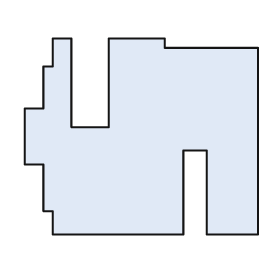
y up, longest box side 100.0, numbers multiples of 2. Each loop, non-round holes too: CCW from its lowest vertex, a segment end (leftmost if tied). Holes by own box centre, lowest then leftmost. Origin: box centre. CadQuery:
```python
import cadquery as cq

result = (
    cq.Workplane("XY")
    .moveTo(-38.0, -42.0)
    .lineTo(18.0, -42.0)
    .lineTo(18.0, -6.0)
    .lineTo(28.0, -6.0)
    .lineTo(28.0, -42.0)
    .lineTo(50.0, -42.0)
    .lineTo(50.0, 38.0)
    .lineTo(10.0, 38.0)
    .lineTo(10.0, 42.0)
    .lineTo(-14.0, 42.0)
    .lineTo(-14.0, 4.0)
    .lineTo(-30.0, 4.0)
    .lineTo(-30.0, 42.0)
    .lineTo(-38.0, 42.0)
    .lineTo(-38.0, 30.0)
    .lineTo(-42.0, 30.0)
    .lineTo(-42.0, 12.0)
    .lineTo(-50.0, 12.0)
    .lineTo(-50.0, -12.0)
    .lineTo(-42.0, -12.0)
    .lineTo(-42.0, -32.0)
    .lineTo(-38.0, -32.0)
    .close()
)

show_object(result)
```